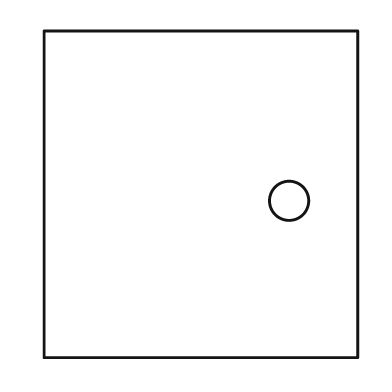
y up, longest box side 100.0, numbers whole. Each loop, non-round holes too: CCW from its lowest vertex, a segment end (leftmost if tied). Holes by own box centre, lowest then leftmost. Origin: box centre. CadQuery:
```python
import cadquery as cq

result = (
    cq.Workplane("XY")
    .moveTo(-48.0, -50.0)
    .lineTo(48.0, -50.0)
    .lineTo(48.0, 50.0)
    .lineTo(-48.0, 50.0)
    .close()
    .moveTo(27.0, -2.0)
    .circle(6.0)
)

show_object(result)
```